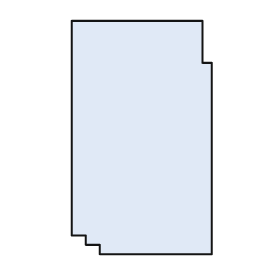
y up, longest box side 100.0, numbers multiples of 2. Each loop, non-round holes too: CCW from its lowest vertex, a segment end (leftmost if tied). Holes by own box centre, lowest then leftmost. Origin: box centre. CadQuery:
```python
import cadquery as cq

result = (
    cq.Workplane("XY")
    .moveTo(-18.0, -50.0)
    .lineTo(30.0, -50.0)
    .lineTo(30.0, 32.0)
    .lineTo(26.0, 32.0)
    .lineTo(26.0, 50.0)
    .lineTo(-30.0, 50.0)
    .lineTo(-30.0, -42.0)
    .lineTo(-24.0, -42.0)
    .lineTo(-24.0, -46.0)
    .lineTo(-18.0, -46.0)
    .close()
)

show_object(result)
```